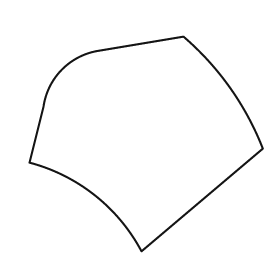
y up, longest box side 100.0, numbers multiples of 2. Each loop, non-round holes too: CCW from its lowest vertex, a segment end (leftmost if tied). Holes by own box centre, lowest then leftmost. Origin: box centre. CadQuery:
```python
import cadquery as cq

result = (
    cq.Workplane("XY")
    .moveTo(-2.0, -46.0)
    .lineTo(50.0, -2.0)
    .threePointArc((36.0, 24.0), (16.0, 46.0))
    .lineTo(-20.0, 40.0)
    .threePointArc((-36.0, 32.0), (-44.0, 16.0))
    .lineTo(-50.0, -8.0)
    .threePointArc((-22.0, -22.0), (-2.0, -46.0))
    .close()
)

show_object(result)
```